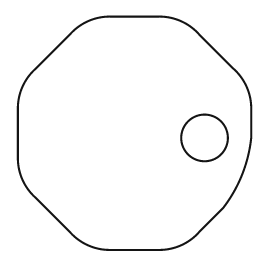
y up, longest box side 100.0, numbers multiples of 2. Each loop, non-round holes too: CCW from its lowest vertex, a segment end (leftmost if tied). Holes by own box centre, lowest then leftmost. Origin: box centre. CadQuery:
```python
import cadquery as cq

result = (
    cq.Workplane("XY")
    .moveTo(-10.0, -50.0)
    .lineTo(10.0, -50.0)
    .threePointArc((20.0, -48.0), (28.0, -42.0))
    .lineTo(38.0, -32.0)
    .threePointArc((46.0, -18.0), (50.0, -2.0))
    .lineTo(50.0, 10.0)
    .threePointArc((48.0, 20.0), (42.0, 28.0))
    .lineTo(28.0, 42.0)
    .threePointArc((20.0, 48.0), (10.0, 50.0))
    .lineTo(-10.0, 50.0)
    .threePointArc((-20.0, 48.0), (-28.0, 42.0))
    .lineTo(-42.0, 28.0)
    .threePointArc((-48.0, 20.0), (-50.0, 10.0))
    .lineTo(-50.0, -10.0)
    .threePointArc((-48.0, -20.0), (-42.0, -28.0))
    .lineTo(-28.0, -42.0)
    .threePointArc((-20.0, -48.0), (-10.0, -50.0))
    .close()
    .moveTo(30.0, -2.0)
    .circle(10.0)
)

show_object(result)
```